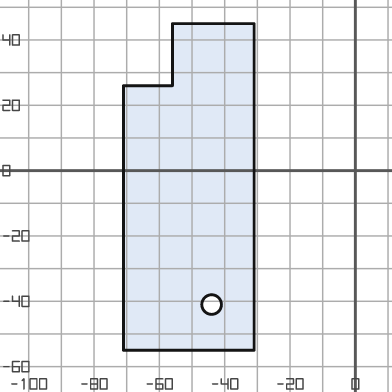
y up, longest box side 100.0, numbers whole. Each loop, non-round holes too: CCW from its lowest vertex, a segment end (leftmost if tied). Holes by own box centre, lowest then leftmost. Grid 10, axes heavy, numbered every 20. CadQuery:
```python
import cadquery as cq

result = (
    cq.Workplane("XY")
    .moveTo(-71.0, -55.0)
    .lineTo(-31.0, -55.0)
    .lineTo(-31.0, 45.0)
    .lineTo(-56.0, 45.0)
    .lineTo(-56.0, 26.0)
    .lineTo(-71.0, 26.0)
    .close()
    .moveTo(-44.0, -41.0)
    .circle(3.0)
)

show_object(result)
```